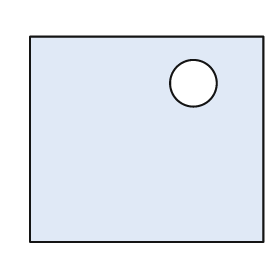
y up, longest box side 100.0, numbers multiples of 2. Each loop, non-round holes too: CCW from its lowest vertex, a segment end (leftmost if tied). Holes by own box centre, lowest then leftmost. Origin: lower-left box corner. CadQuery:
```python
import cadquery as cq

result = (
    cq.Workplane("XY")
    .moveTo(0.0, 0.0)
    .lineTo(100.0, 0.0)
    .lineTo(100.0, 88.0)
    .lineTo(0.0, 88.0)
    .close()
    .moveTo(70.0, 68.0)
    .circle(10.0)
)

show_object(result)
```